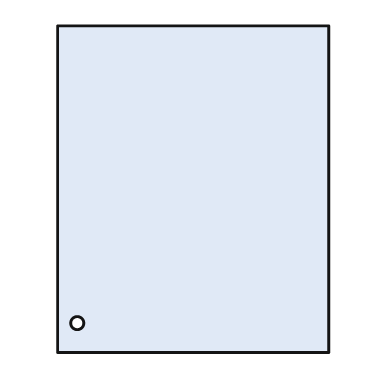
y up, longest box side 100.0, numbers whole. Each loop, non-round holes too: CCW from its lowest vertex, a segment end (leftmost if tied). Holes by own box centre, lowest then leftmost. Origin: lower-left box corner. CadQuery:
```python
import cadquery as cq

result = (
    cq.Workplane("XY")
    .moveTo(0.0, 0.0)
    .lineTo(83.0, 0.0)
    .lineTo(83.0, 100.0)
    .lineTo(0.0, 100.0)
    .close()
    .moveTo(6.0, 9.0)
    .circle(2.0)
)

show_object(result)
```